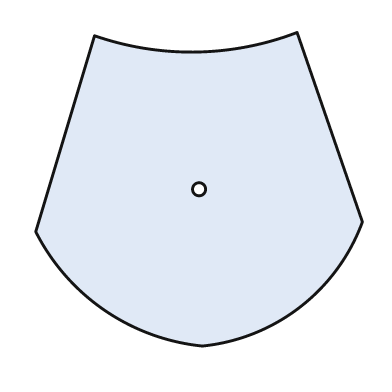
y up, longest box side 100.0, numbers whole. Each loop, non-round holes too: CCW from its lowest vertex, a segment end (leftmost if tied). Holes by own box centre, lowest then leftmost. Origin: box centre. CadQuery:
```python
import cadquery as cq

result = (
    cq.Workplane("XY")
    .moveTo(1.0, -48.0)
    .threePointArc((31.0, -36.0), (50.0, -10.0))
    .lineTo(30.0, 48.0)
    .threePointArc((-1.0, 42.0), (-32.0, 47.0))
    .lineTo(-50.0, -13.0)
    .threePointArc((-29.0, -37.0), (1.0, -48.0))
    .close()
    .moveTo(0.0, 0.0)
    .circle(2.0)
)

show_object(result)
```